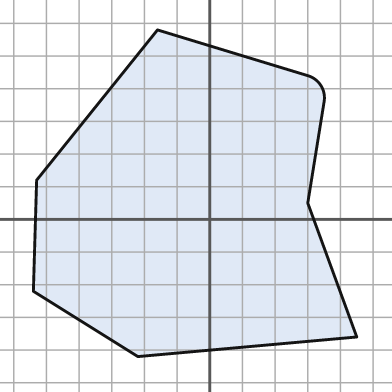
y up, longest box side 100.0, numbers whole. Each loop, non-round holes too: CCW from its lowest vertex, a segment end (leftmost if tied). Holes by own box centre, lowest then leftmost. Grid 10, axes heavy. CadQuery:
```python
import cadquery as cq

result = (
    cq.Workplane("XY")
    .moveTo(-22.0, -42.0)
    .lineTo(45.0, -36.0)
    .lineTo(30.0, 5.0)
    .lineTo(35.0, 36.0)
    .threePointArc((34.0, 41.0), (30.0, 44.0))
    .lineTo(-16.0, 58.0)
    .lineTo(-53.0, 12.0)
    .lineTo(-54.0, -22.0)
    .close()
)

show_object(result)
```